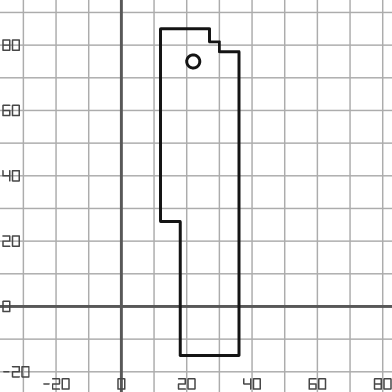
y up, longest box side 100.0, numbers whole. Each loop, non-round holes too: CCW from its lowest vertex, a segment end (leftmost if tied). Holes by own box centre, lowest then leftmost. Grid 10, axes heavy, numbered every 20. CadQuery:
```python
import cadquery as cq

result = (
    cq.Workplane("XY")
    .moveTo(18.0, -15.0)
    .lineTo(36.0, -15.0)
    .lineTo(36.0, 78.0)
    .lineTo(30.0, 78.0)
    .lineTo(30.0, 81.0)
    .lineTo(27.0, 81.0)
    .lineTo(27.0, 85.0)
    .lineTo(12.0, 85.0)
    .lineTo(12.0, 26.0)
    .lineTo(18.0, 26.0)
    .close()
    .moveTo(22.0, 75.0)
    .circle(2.0)
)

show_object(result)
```